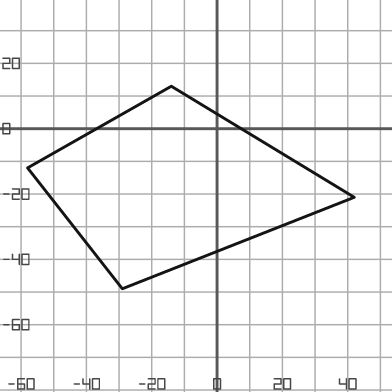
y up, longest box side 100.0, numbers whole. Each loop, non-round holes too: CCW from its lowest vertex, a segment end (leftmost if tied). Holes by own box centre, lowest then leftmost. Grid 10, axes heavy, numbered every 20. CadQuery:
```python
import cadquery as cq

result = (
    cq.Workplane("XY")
    .moveTo(-29.0, -49.0)
    .lineTo(42.0, -21.0)
    .lineTo(-14.0, 13.0)
    .lineTo(-58.0, -12.0)
    .close()
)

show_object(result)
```